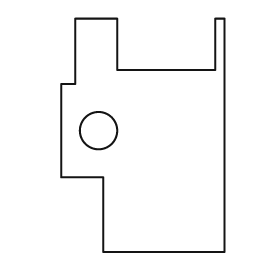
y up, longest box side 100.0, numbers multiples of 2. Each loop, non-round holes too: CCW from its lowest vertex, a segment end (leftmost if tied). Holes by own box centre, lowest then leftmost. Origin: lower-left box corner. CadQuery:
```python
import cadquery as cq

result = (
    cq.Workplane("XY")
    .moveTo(18.0, 0.0)
    .lineTo(70.0, 0.0)
    .lineTo(70.0, 100.0)
    .lineTo(66.0, 100.0)
    .lineTo(66.0, 78.0)
    .lineTo(24.0, 78.0)
    .lineTo(24.0, 100.0)
    .lineTo(6.0, 100.0)
    .lineTo(6.0, 72.0)
    .lineTo(0.0, 72.0)
    .lineTo(0.0, 32.0)
    .lineTo(18.0, 32.0)
    .close()
    .moveTo(16.0, 52.0)
    .circle(8.0)
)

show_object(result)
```